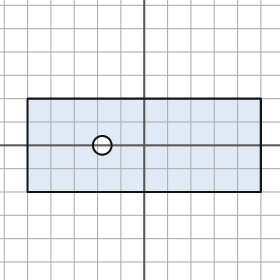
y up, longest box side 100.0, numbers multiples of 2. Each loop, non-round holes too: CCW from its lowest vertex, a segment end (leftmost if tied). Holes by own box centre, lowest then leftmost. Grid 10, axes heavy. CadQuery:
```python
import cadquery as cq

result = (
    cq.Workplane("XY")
    .moveTo(-50.0, -20.0)
    .lineTo(50.0, -20.0)
    .lineTo(50.0, 20.0)
    .lineTo(-50.0, 20.0)
    .close()
    .moveTo(-18.0, 0.0)
    .circle(4.0)
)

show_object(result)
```